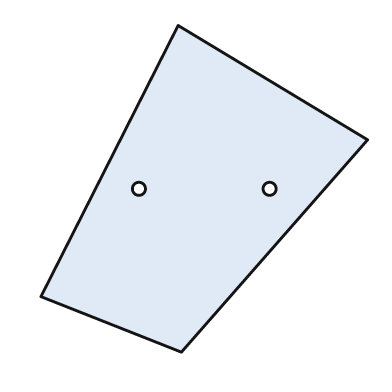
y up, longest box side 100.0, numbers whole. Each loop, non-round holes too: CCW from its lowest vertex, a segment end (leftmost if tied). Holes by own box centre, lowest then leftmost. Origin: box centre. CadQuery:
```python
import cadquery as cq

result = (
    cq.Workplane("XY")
    .moveTo(-7.0, -50.0)
    .lineTo(50.0, 15.0)
    .lineTo(-8.0, 50.0)
    .lineTo(-50.0, -33.0)
    .close()
    .moveTo(-20.0, 0.0)
    .circle(2.0)
    .moveTo(20.0, 0.0)
    .circle(2.0)
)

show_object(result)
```